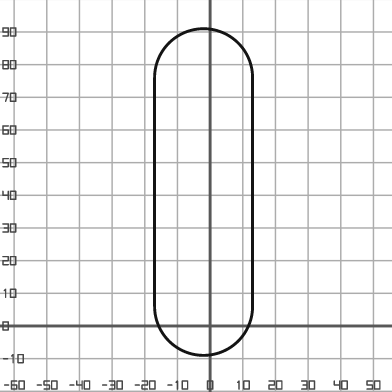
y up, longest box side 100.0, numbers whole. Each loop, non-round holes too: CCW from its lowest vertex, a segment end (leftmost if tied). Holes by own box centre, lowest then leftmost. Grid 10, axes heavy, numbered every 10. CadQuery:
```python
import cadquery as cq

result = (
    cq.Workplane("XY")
    .moveTo(-17.0, 6.0)
    .threePointArc((-2.0, -9.0), (13.0, 6.0))
    .lineTo(13.0, 76.0)
    .threePointArc((-2.0, 91.0), (-17.0, 76.0))
    .close()
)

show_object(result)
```